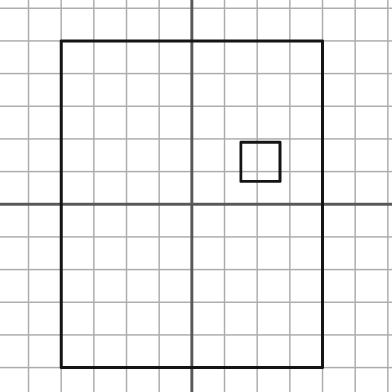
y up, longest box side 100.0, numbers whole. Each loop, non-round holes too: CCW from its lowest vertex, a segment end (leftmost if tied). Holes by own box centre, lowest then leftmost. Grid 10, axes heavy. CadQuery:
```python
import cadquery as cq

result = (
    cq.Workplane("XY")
    .moveTo(-40.0, -50.0)
    .lineTo(40.0, -50.0)
    .lineTo(40.0, 50.0)
    .lineTo(-40.0, 50.0)
    .close()
    .moveTo(15.0, 7.0)
    .lineTo(27.0, 7.0)
    .lineTo(27.0, 19.0)
    .lineTo(15.0, 19.0)
    .close()
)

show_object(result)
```